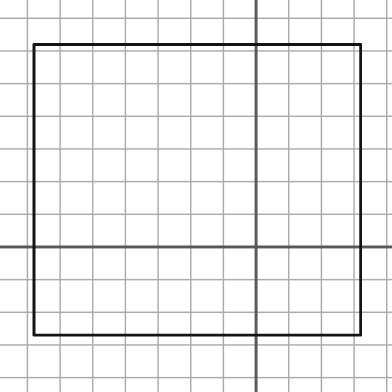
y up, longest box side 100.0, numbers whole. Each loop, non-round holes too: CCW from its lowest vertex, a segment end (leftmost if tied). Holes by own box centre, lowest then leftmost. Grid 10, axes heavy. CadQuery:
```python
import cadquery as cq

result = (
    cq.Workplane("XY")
    .moveTo(-68.0, -27.0)
    .lineTo(32.0, -27.0)
    .lineTo(32.0, 62.0)
    .lineTo(-68.0, 62.0)
    .close()
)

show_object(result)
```